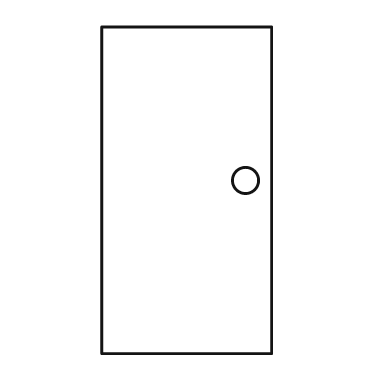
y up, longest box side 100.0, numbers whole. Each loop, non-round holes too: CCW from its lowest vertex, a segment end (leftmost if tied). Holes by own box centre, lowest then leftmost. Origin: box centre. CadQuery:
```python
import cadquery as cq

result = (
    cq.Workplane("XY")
    .moveTo(-26.0, -50.0)
    .lineTo(26.0, -50.0)
    .lineTo(26.0, 50.0)
    .lineTo(-26.0, 50.0)
    .close()
    .moveTo(18.0, 3.0)
    .circle(4.0)
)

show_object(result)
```